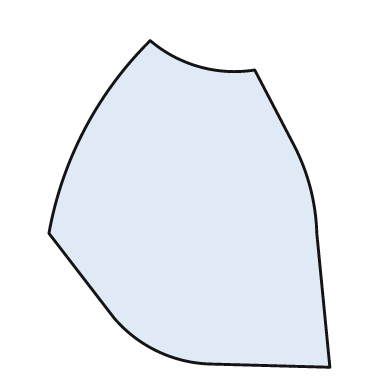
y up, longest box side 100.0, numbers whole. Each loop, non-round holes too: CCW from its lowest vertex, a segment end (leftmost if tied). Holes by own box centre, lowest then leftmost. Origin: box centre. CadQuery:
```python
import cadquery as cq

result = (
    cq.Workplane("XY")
    .moveTo(43.0, -50.0)
    .lineTo(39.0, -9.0)
    .threePointArc((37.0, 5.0), (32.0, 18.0))
    .lineTo(20.0, 41.0)
    .threePointArc((3.0, 42.0), (-12.0, 50.0))
    .threePointArc((-32.0, 23.0), (-43.0, -9.0))
    .lineTo(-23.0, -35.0)
    .threePointArc((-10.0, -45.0), (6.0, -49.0))
    .close()
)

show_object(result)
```